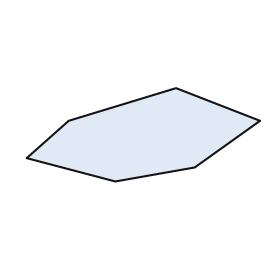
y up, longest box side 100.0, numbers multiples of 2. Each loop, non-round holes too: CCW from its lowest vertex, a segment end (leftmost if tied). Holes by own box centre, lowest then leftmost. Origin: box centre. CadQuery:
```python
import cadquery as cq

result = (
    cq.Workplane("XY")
    .moveTo(-12.0, -20.0)
    .lineTo(22.0, -14.0)
    .lineTo(50.0, 6.0)
    .lineTo(14.0, 20.0)
    .lineTo(-32.0, 6.0)
    .lineTo(-50.0, -10.0)
    .close()
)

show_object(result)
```